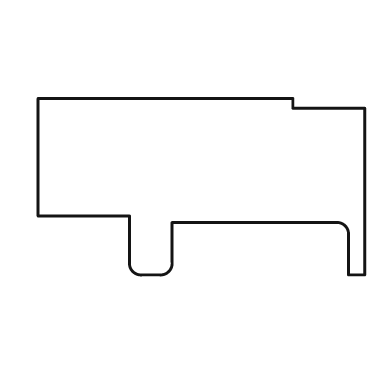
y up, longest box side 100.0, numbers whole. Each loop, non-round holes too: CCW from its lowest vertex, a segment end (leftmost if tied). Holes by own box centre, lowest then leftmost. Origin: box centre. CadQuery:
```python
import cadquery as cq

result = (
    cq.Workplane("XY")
    .moveTo(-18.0, -27.0)
    .lineTo(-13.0, -27.0)
    .threePointArc((-10.0, -26.0), (-9.0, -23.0))
    .lineTo(-9.0, -11.0)
    .lineTo(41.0, -11.0)
    .threePointArc((44.0, -12.0), (45.0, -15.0))
    .lineTo(45.0, -27.0)
    .lineTo(50.0, -27.0)
    .lineTo(50.0, 24.0)
    .lineTo(28.0, 24.0)
    .lineTo(28.0, 27.0)
    .lineTo(-50.0, 27.0)
    .lineTo(-50.0, -9.0)
    .lineTo(-22.0, -9.0)
    .lineTo(-22.0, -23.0)
    .threePointArc((-21.0, -26.0), (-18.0, -27.0))
    .close()
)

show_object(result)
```